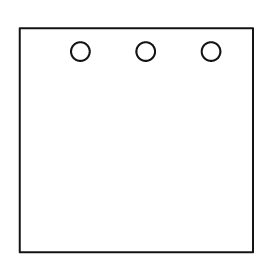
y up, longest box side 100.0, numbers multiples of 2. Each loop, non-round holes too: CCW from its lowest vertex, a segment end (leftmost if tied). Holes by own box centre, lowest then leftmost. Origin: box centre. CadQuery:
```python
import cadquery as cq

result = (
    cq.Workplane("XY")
    .moveTo(-50.0, -48.0)
    .lineTo(50.0, -48.0)
    .lineTo(50.0, 48.0)
    .lineTo(-50.0, 48.0)
    .close()
    .moveTo(-24.0, 38.0)
    .circle(4.0)
    .moveTo(4.0, 38.0)
    .circle(4.0)
    .moveTo(32.0, 38.0)
    .circle(4.0)
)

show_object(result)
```